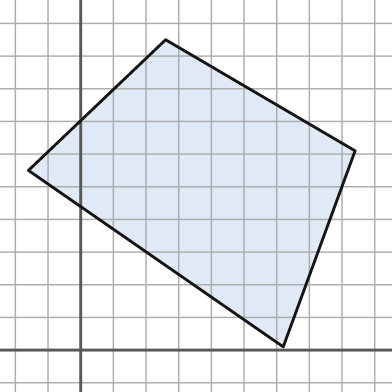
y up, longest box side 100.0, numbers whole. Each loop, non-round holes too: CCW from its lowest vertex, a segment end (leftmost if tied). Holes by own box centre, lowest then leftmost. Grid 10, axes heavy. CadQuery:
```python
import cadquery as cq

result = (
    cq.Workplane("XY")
    .moveTo(62.0, 1.0)
    .lineTo(84.0, 61.0)
    .lineTo(26.0, 95.0)
    .lineTo(-16.0, 55.0)
    .close()
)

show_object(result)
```